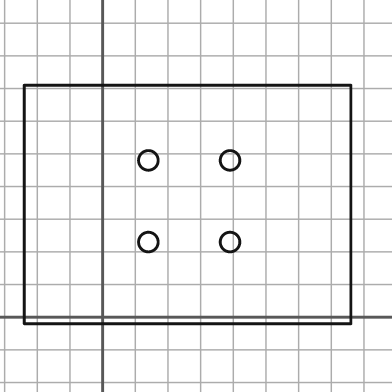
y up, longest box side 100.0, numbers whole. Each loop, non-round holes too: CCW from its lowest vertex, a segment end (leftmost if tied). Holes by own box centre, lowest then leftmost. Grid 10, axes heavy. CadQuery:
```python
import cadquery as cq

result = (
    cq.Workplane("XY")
    .moveTo(-24.0, -2.0)
    .lineTo(76.0, -2.0)
    .lineTo(76.0, 71.0)
    .lineTo(-24.0, 71.0)
    .close()
    .moveTo(14.0, 23.0)
    .circle(3.0)
    .moveTo(39.0, 23.0)
    .circle(3.0)
    .moveTo(14.0, 48.0)
    .circle(3.0)
    .moveTo(39.0, 48.0)
    .circle(3.0)
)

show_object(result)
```